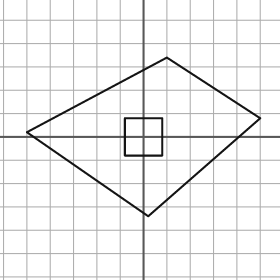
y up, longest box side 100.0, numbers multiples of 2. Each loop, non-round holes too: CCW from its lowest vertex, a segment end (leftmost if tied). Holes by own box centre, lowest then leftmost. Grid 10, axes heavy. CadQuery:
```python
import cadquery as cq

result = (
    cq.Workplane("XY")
    .moveTo(2.0, -34.0)
    .lineTo(50.0, 8.0)
    .lineTo(10.0, 34.0)
    .lineTo(-50.0, 2.0)
    .close()
    .moveTo(-8.0, -8.0)
    .lineTo(8.0, -8.0)
    .lineTo(8.0, 8.0)
    .lineTo(-8.0, 8.0)
    .close()
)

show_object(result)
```